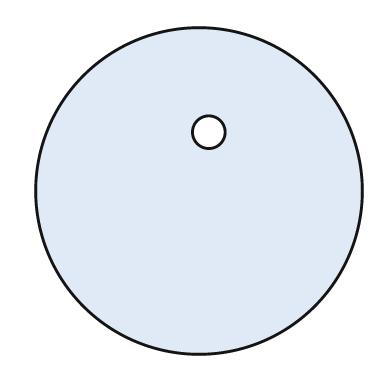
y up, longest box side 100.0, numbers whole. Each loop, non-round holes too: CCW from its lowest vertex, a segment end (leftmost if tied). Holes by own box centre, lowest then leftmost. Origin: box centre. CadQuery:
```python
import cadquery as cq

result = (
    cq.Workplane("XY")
    .moveTo(0.0, 0.0)
    .circle(50.0)
    .moveTo(3.0, 18.0)
    .circle(5.0)
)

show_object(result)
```